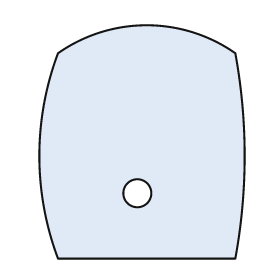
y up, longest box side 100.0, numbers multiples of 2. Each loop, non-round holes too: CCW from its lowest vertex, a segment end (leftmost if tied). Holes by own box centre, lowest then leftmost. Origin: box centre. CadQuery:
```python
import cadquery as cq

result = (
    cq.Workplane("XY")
    .moveTo(-36.0, -50.0)
    .lineTo(40.0, -50.0)
    .threePointArc((44.0, -6.0), (40.0, 38.0))
    .threePointArc((2.0, 50.0), (-36.0, 38.0))
    .threePointArc((-44.0, -6.0), (-36.0, -50.0))
    .close()
    .moveTo(-2.0, -22.0)
    .circle(6.0)
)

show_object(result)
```